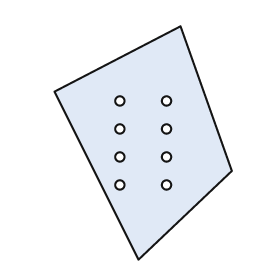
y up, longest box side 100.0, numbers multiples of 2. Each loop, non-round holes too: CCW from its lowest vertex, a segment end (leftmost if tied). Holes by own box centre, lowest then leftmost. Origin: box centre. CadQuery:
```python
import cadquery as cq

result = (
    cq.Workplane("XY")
    .moveTo(-2.0, -50.0)
    .lineTo(38.0, -12.0)
    .lineTo(16.0, 50.0)
    .lineTo(-38.0, 22.0)
    .close()
    .moveTo(-10.0, -18.0)
    .circle(2.0)
    .moveTo(10.0, -18.0)
    .circle(2.0)
    .moveTo(-10.0, -6.0)
    .circle(2.0)
    .moveTo(10.0, -6.0)
    .circle(2.0)
    .moveTo(-10.0, 6.0)
    .circle(2.0)
    .moveTo(10.0, 6.0)
    .circle(2.0)
    .moveTo(-10.0, 18.0)
    .circle(2.0)
    .moveTo(10.0, 18.0)
    .circle(2.0)
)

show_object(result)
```